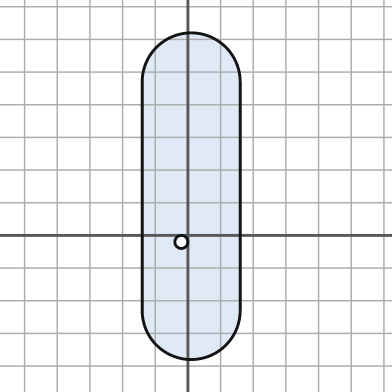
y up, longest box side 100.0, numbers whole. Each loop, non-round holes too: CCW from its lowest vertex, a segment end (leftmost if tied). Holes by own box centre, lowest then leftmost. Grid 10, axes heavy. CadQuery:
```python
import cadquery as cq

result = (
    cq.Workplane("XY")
    .moveTo(-14.0, -23.0)
    .threePointArc((1.0, -38.0), (16.0, -23.0))
    .lineTo(16.0, 47.0)
    .threePointArc((1.0, 62.0), (-14.0, 47.0))
    .close()
    .moveTo(-2.0, -2.0)
    .circle(2.0)
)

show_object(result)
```